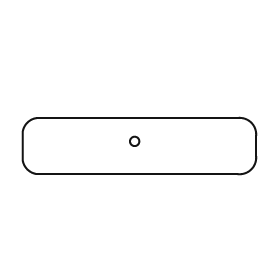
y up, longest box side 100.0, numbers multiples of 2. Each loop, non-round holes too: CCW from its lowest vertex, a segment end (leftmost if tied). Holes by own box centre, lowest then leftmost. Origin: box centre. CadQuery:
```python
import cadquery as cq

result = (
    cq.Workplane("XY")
    .moveTo(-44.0, -12.0)
    .lineTo(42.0, -12.0)
    .threePointArc((48.0, -10.0), (50.0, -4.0))
    .lineTo(50.0, 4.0)
    .threePointArc((48.0, 10.0), (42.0, 12.0))
    .lineTo(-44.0, 12.0)
    .threePointArc((-48.0, 10.0), (-50.0, 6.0))
    .lineTo(-50.0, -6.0)
    .threePointArc((-48.0, -10.0), (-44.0, -12.0))
    .close()
    .moveTo(-2.0, 2.0)
    .circle(2.0)
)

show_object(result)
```